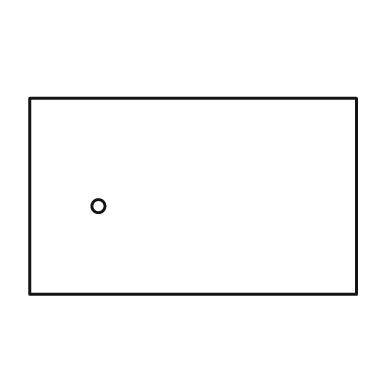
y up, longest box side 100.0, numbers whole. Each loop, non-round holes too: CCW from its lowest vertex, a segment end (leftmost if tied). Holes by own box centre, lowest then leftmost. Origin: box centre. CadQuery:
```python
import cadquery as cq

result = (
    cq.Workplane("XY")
    .moveTo(-50.0, -30.0)
    .lineTo(50.0, -30.0)
    .lineTo(50.0, 30.0)
    .lineTo(-50.0, 30.0)
    .close()
    .moveTo(-29.0, -3.0)
    .circle(2.0)
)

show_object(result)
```